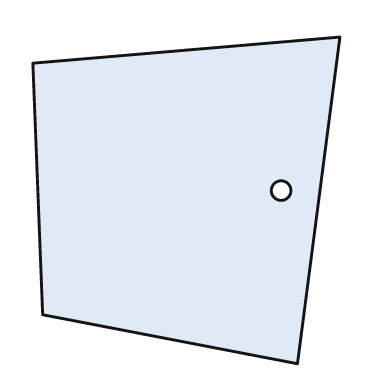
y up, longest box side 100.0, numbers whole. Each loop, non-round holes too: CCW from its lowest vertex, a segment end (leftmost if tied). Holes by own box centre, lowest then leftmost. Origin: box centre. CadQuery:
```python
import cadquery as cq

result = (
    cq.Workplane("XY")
    .moveTo(34.0, -50.0)
    .lineTo(47.0, 50.0)
    .lineTo(-47.0, 42.0)
    .lineTo(-44.0, -35.0)
    .close()
    .moveTo(29.0, 3.0)
    .circle(3.0)
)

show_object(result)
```